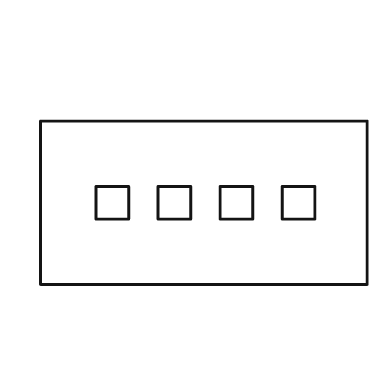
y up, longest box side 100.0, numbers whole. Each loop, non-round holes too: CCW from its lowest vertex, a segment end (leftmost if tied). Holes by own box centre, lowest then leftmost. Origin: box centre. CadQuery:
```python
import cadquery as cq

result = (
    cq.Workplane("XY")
    .moveTo(-50.0, -25.0)
    .lineTo(50.0, -25.0)
    .lineTo(50.0, 25.0)
    .lineTo(-50.0, 25.0)
    .close()
    .moveTo(-33.0, -5.0)
    .lineTo(-23.0, -5.0)
    .lineTo(-23.0, 5.0)
    .lineTo(-33.0, 5.0)
    .close()
    .moveTo(-14.0, -5.0)
    .lineTo(-4.0, -5.0)
    .lineTo(-4.0, 5.0)
    .lineTo(-14.0, 5.0)
    .close()
    .moveTo(5.0, -5.0)
    .lineTo(15.0, -5.0)
    .lineTo(15.0, 5.0)
    .lineTo(5.0, 5.0)
    .close()
    .moveTo(24.0, -5.0)
    .lineTo(34.0, -5.0)
    .lineTo(34.0, 5.0)
    .lineTo(24.0, 5.0)
    .close()
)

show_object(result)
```